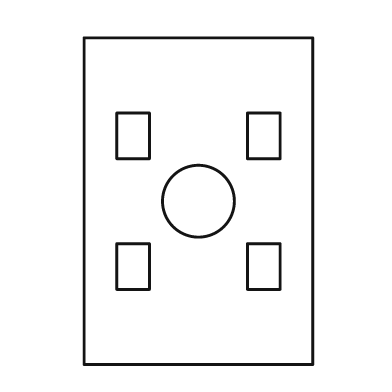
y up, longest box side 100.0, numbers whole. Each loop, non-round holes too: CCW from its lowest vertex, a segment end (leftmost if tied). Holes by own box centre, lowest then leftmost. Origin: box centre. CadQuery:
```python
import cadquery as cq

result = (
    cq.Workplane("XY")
    .moveTo(-35.0, -50.0)
    .lineTo(35.0, -50.0)
    .lineTo(35.0, 50.0)
    .lineTo(-35.0, 50.0)
    .close()
    .moveTo(-25.0, -27.0)
    .lineTo(-15.0, -27.0)
    .lineTo(-15.0, -13.0)
    .lineTo(-25.0, -13.0)
    .close()
    .moveTo(15.0, -27.0)
    .lineTo(25.0, -27.0)
    .lineTo(25.0, -13.0)
    .lineTo(15.0, -13.0)
    .close()
    .moveTo(0.0, 0.0)
    .circle(11.0)
    .moveTo(-25.0, 13.0)
    .lineTo(-15.0, 13.0)
    .lineTo(-15.0, 27.0)
    .lineTo(-25.0, 27.0)
    .close()
    .moveTo(15.0, 13.0)
    .lineTo(25.0, 13.0)
    .lineTo(25.0, 27.0)
    .lineTo(15.0, 27.0)
    .close()
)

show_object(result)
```